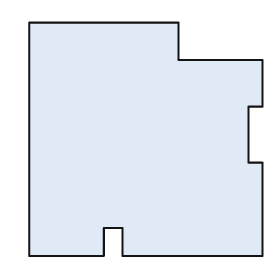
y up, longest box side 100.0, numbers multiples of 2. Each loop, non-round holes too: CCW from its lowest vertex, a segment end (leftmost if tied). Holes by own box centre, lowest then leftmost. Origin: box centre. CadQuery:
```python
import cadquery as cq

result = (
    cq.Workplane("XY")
    .moveTo(-50.0, -50.0)
    .lineTo(-18.0, -50.0)
    .lineTo(-18.0, -38.0)
    .lineTo(-10.0, -38.0)
    .lineTo(-10.0, -50.0)
    .lineTo(50.0, -50.0)
    .lineTo(50.0, -10.0)
    .lineTo(44.0, -10.0)
    .lineTo(44.0, 14.0)
    .lineTo(50.0, 14.0)
    .lineTo(50.0, 34.0)
    .lineTo(14.0, 34.0)
    .lineTo(14.0, 50.0)
    .lineTo(-50.0, 50.0)
    .close()
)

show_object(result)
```